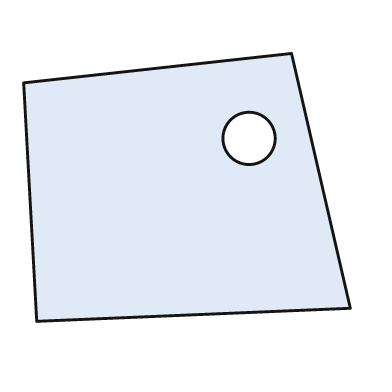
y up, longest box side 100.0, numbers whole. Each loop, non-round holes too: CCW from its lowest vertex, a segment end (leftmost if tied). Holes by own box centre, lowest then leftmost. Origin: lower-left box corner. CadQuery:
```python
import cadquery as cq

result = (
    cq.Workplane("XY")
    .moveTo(4.0, 0.0)
    .lineTo(100.0, 4.0)
    .lineTo(82.0, 82.0)
    .lineTo(0.0, 73.0)
    .close()
    .moveTo(69.0, 56.0)
    .circle(8.0)
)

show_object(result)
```